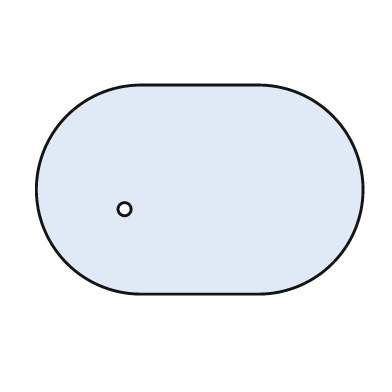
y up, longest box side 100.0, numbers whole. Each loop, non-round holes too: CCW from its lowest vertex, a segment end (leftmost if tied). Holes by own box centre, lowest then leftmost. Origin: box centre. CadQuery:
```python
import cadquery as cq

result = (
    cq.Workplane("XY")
    .moveTo(-18.0, -32.0)
    .lineTo(18.0, -32.0)
    .threePointArc((50.0, 0.0), (18.0, 32.0))
    .lineTo(-18.0, 32.0)
    .threePointArc((-50.0, 0.0), (-18.0, -32.0))
    .close()
    .moveTo(-23.0, -6.0)
    .circle(2.0)
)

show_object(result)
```